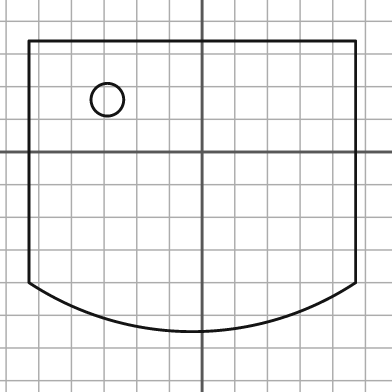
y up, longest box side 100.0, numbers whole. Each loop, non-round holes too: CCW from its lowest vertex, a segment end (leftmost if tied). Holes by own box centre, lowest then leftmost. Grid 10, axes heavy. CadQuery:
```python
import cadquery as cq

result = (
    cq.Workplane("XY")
    .moveTo(-53.0, -40.0)
    .threePointArc((-3.0, -55.0), (47.0, -40.0))
    .lineTo(47.0, 34.0)
    .lineTo(-53.0, 34.0)
    .close()
    .moveTo(-29.0, 16.0)
    .circle(5.0)
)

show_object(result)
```